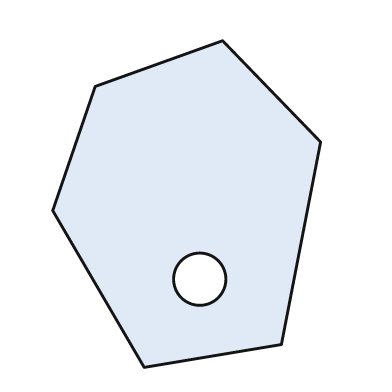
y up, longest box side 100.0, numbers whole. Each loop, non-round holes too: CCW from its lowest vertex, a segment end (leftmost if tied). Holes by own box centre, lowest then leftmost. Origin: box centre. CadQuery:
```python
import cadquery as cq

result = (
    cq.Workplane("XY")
    .moveTo(-13.0, -50.0)
    .lineTo(29.0, -43.0)
    .lineTo(41.0, 19.0)
    .lineTo(11.0, 50.0)
    .lineTo(-28.0, 36.0)
    .lineTo(-41.0, -2.0)
    .close()
    .moveTo(4.0, -23.0)
    .circle(8.0)
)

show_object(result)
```